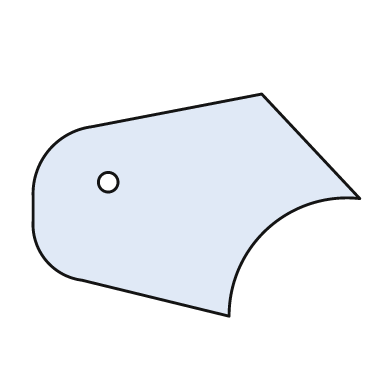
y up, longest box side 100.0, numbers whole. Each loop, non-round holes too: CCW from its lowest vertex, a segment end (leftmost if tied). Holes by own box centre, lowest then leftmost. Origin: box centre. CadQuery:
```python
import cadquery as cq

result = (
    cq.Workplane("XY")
    .moveTo(10.0, -34.0)
    .threePointArc((22.0, -7.0), (50.0, 2.0))
    .lineTo(20.0, 34.0)
    .lineTo(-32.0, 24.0)
    .threePointArc((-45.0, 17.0), (-50.0, 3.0))
    .lineTo(-50.0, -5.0)
    .threePointArc((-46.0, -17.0), (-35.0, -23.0))
    .close()
    .moveTo(-27.0, 7.0)
    .circle(3.0)
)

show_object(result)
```